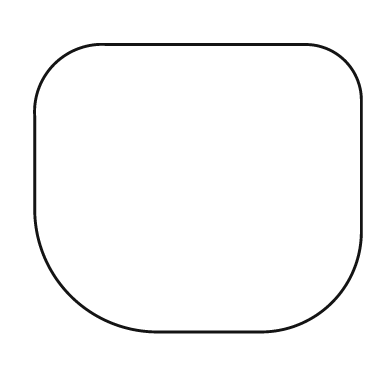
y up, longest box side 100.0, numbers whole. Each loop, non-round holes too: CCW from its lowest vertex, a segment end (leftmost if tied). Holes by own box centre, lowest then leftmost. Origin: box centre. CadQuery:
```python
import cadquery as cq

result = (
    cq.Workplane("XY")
    .moveTo(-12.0, -44.0)
    .lineTo(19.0, -44.0)
    .threePointArc((41.0, -35.0), (50.0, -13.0))
    .lineTo(50.0, 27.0)
    .threePointArc((45.0, 39.0), (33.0, 44.0))
    .lineTo(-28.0, 44.0)
    .threePointArc((-44.0, 38.0), (-50.0, 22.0))
    .lineTo(-50.0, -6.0)
    .threePointArc((-39.0, -33.0), (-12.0, -44.0))
    .close()
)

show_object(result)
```